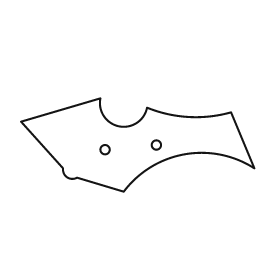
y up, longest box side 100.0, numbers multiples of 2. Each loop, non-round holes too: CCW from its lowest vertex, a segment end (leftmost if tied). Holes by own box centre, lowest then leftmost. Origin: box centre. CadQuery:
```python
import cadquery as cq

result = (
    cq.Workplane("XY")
    .moveTo(-6.0, -20.0)
    .threePointArc((20.0, -4.0), (50.0, -10.0))
    .lineTo(40.0, 14.0)
    .threePointArc((22.0, 12.0), (4.0, 16.0))
    .threePointArc((-8.0, 8.0), (-16.0, 20.0))
    .lineTo(-50.0, 10.0)
    .lineTo(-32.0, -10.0)
    .threePointArc((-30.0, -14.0), (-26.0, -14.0))
    .close()
    .moveTo(-14.0, -2.0)
    .circle(2.0)
    .moveTo(8.0, 0.0)
    .circle(2.0)
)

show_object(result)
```